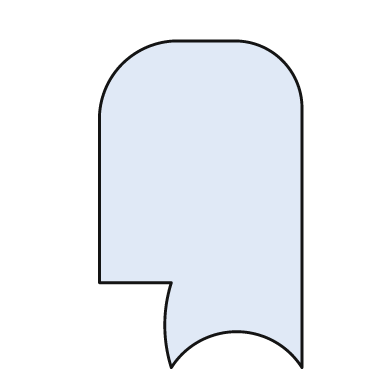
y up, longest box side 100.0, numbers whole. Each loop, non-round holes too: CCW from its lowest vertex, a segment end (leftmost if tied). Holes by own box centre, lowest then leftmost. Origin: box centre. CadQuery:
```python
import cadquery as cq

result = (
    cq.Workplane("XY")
    .moveTo(-9.0, -50.0)
    .threePointArc((11.0, -39.0), (31.0, -50.0))
    .lineTo(31.0, 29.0)
    .threePointArc((25.0, 44.0), (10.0, 50.0))
    .lineTo(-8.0, 50.0)
    .threePointArc((-24.0, 43.0), (-31.0, 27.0))
    .lineTo(-31.0, -24.0)
    .lineTo(-9.0, -24.0)
    .threePointArc((-11.0, -37.0), (-9.0, -50.0))
    .close()
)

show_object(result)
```